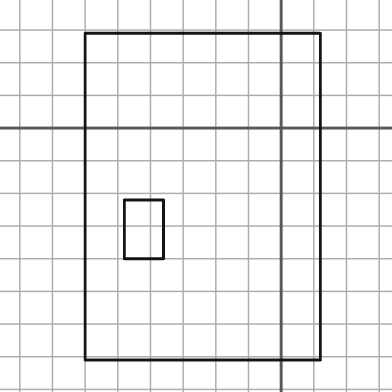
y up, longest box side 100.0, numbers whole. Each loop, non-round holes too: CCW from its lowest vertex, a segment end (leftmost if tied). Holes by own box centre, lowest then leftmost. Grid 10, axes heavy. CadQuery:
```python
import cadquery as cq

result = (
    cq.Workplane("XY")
    .moveTo(-60.0, -71.0)
    .lineTo(12.0, -71.0)
    .lineTo(12.0, 29.0)
    .lineTo(-60.0, 29.0)
    .close()
    .moveTo(-48.0, -40.0)
    .lineTo(-36.0, -40.0)
    .lineTo(-36.0, -22.0)
    .lineTo(-48.0, -22.0)
    .close()
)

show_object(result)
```